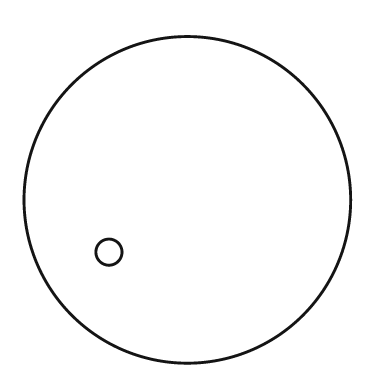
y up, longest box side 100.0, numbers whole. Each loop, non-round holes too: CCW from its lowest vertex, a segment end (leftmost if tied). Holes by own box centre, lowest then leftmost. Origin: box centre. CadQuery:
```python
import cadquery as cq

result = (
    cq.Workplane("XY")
    .moveTo(0.0, 0.0)
    .circle(50.0)
    .moveTo(-24.0, -16.0)
    .circle(4.0)
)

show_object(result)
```